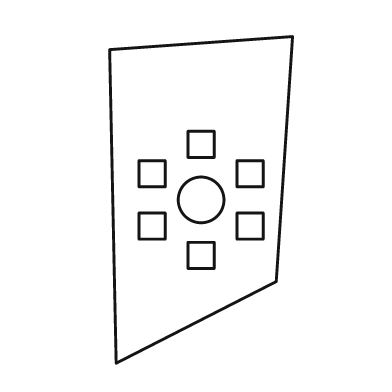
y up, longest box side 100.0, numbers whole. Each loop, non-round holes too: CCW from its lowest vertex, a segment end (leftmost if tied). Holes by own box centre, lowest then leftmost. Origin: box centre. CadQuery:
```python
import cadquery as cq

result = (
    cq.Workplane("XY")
    .moveTo(-26.0, -50.0)
    .lineTo(23.0, -25.0)
    .lineTo(28.0, 50.0)
    .lineTo(-28.0, 46.0)
    .close()
    .moveTo(-4.0, -21.0)
    .lineTo(4.0, -21.0)
    .lineTo(4.0, -13.0)
    .lineTo(-4.0, -13.0)
    .close()
    .moveTo(-19.0, -12.0)
    .lineTo(-11.0, -12.0)
    .lineTo(-11.0, -4.0)
    .lineTo(-19.0, -4.0)
    .close()
    .moveTo(11.0, -12.0)
    .lineTo(19.0, -12.0)
    .lineTo(19.0, -4.0)
    .lineTo(11.0, -4.0)
    .close()
    .moveTo(0.0, 0.0)
    .circle(7.0)
    .moveTo(-19.0, 4.0)
    .lineTo(-11.0, 4.0)
    .lineTo(-11.0, 12.0)
    .lineTo(-19.0, 12.0)
    .close()
    .moveTo(11.0, 4.0)
    .lineTo(19.0, 4.0)
    .lineTo(19.0, 12.0)
    .lineTo(11.0, 12.0)
    .close()
    .moveTo(-4.0, 13.0)
    .lineTo(4.0, 13.0)
    .lineTo(4.0, 21.0)
    .lineTo(-4.0, 21.0)
    .close()
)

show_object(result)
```